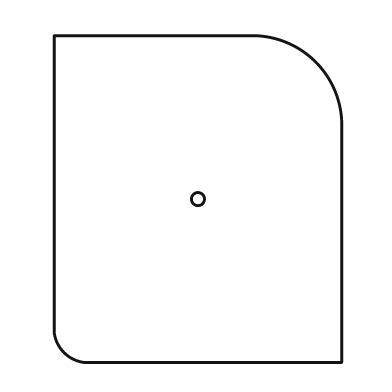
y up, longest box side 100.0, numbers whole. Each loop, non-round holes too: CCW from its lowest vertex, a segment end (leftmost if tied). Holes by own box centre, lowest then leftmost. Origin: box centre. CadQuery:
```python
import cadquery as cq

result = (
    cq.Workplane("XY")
    .moveTo(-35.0, -50.0)
    .lineTo(44.0, -50.0)
    .lineTo(44.0, 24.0)
    .threePointArc((36.0, 42.0), (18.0, 50.0))
    .lineTo(-44.0, 50.0)
    .lineTo(-44.0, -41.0)
    .threePointArc((-41.0, -47.0), (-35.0, -50.0))
    .close()
    .moveTo(0.0, 0.0)
    .circle(2.0)
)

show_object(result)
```